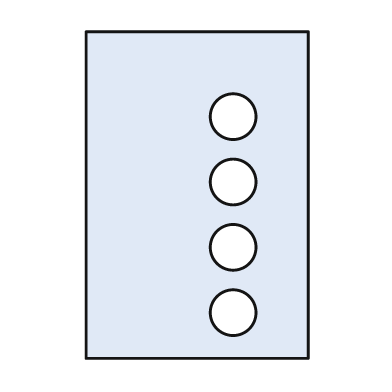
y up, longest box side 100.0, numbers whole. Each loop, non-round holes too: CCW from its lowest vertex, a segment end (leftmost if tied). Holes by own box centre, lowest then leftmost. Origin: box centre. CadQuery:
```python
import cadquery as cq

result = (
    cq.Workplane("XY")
    .moveTo(-34.0, -50.0)
    .lineTo(34.0, -50.0)
    .lineTo(34.0, 50.0)
    .lineTo(-34.0, 50.0)
    .close()
    .moveTo(11.0, -36.0)
    .circle(7.0)
    .moveTo(11.0, -16.0)
    .circle(7.0)
    .moveTo(11.0, 4.0)
    .circle(7.0)
    .moveTo(11.0, 24.0)
    .circle(7.0)
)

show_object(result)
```